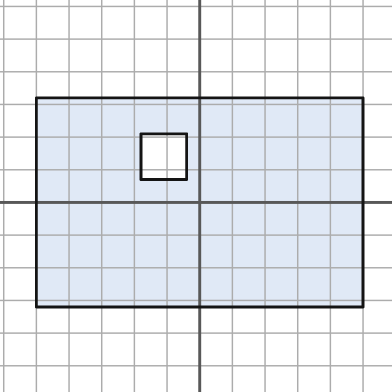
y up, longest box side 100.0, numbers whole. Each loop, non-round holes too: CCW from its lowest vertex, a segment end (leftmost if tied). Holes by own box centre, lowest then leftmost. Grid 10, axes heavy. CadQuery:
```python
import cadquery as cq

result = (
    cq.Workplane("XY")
    .moveTo(-50.0, -32.0)
    .lineTo(50.0, -32.0)
    .lineTo(50.0, 32.0)
    .lineTo(-50.0, 32.0)
    .close()
    .moveTo(-18.0, 7.0)
    .lineTo(-4.0, 7.0)
    .lineTo(-4.0, 21.0)
    .lineTo(-18.0, 21.0)
    .close()
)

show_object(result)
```